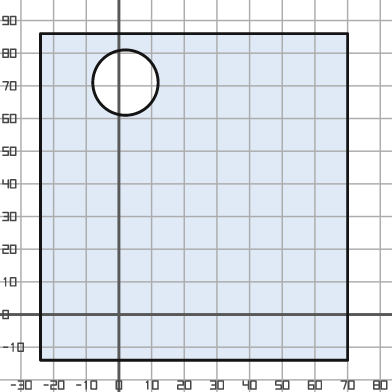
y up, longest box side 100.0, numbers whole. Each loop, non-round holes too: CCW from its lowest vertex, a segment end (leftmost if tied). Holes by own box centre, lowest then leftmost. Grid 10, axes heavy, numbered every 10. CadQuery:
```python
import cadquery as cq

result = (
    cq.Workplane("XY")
    .moveTo(-24.0, -14.0)
    .lineTo(70.0, -14.0)
    .lineTo(70.0, 86.0)
    .lineTo(-24.0, 86.0)
    .close()
    .moveTo(2.0, 71.0)
    .circle(10.0)
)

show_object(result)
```